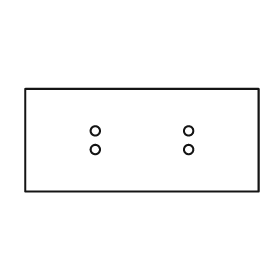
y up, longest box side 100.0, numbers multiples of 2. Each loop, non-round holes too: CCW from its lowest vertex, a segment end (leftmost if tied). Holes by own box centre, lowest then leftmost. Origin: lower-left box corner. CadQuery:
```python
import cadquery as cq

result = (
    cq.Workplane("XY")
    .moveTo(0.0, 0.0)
    .lineTo(100.0, 0.0)
    .lineTo(100.0, 44.0)
    .lineTo(0.0, 44.0)
    .close()
    .moveTo(30.0, 18.0)
    .circle(2.0)
    .moveTo(70.0, 18.0)
    .circle(2.0)
    .moveTo(30.0, 26.0)
    .circle(2.0)
    .moveTo(70.0, 26.0)
    .circle(2.0)
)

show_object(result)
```